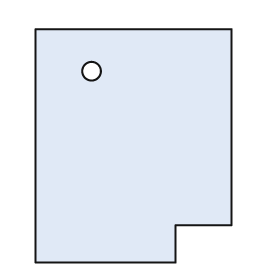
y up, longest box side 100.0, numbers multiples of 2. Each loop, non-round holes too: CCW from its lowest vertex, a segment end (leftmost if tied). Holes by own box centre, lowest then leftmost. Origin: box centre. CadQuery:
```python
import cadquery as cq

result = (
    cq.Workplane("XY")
    .moveTo(-42.0, -50.0)
    .lineTo(18.0, -50.0)
    .lineTo(18.0, -34.0)
    .lineTo(42.0, -34.0)
    .lineTo(42.0, 50.0)
    .lineTo(-42.0, 50.0)
    .close()
    .moveTo(-18.0, 32.0)
    .circle(4.0)
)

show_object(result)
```